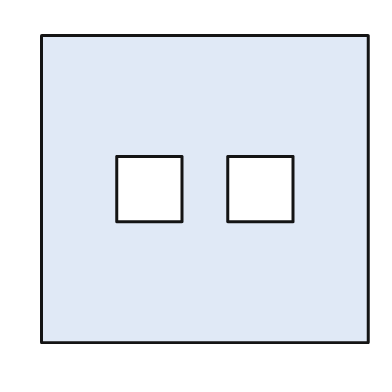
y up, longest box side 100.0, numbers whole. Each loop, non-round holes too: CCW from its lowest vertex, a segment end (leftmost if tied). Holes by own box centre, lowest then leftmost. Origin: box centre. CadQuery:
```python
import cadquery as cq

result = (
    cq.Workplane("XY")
    .moveTo(-50.0, -47.0)
    .lineTo(50.0, -47.0)
    .lineTo(50.0, 47.0)
    .lineTo(-50.0, 47.0)
    .close()
    .moveTo(-27.0, -10.0)
    .lineTo(-7.0, -10.0)
    .lineTo(-7.0, 10.0)
    .lineTo(-27.0, 10.0)
    .close()
    .moveTo(7.0, -10.0)
    .lineTo(27.0, -10.0)
    .lineTo(27.0, 10.0)
    .lineTo(7.0, 10.0)
    .close()
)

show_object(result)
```